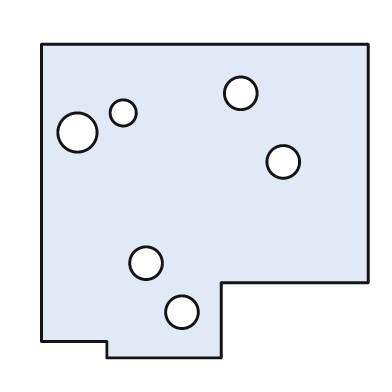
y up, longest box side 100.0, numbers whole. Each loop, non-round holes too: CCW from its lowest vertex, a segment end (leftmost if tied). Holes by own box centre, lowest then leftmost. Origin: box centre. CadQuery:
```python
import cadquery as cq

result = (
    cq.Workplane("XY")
    .moveTo(-30.0, -48.0)
    .lineTo(5.0, -48.0)
    .lineTo(5.0, -25.0)
    .lineTo(50.0, -25.0)
    .lineTo(50.0, 48.0)
    .lineTo(-50.0, 48.0)
    .lineTo(-50.0, -43.0)
    .lineTo(-30.0, -43.0)
    .close()
    .moveTo(-7.0, -34.0)
    .circle(5.0)
    .moveTo(-18.0, -19.0)
    .circle(5.0)
    .moveTo(24.0, 12.0)
    .circle(5.0)
    .moveTo(-39.0, 21.0)
    .circle(6.0)
    .moveTo(-25.0, 27.0)
    .circle(4.0)
    .moveTo(11.0, 33.0)
    .circle(5.0)
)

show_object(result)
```